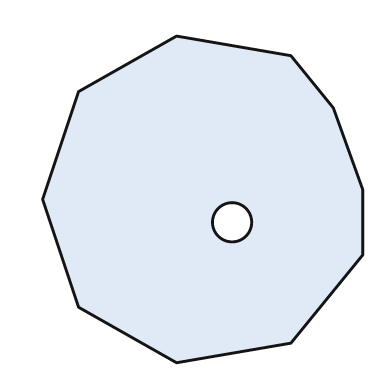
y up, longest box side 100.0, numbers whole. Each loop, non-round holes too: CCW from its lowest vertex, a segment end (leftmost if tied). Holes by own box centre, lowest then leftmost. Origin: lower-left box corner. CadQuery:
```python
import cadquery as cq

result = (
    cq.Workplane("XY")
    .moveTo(41.0, 0.0)
    .lineTo(76.0, 6.0)
    .lineTo(98.0, 33.0)
    .lineTo(98.0, 53.0)
    .lineTo(89.0, 78.0)
    .lineTo(76.0, 94.0)
    .lineTo(41.0, 100.0)
    .lineTo(11.0, 83.0)
    .lineTo(0.0, 50.0)
    .lineTo(11.0, 17.0)
    .close()
    .moveTo(58.0, 43.0)
    .circle(6.0)
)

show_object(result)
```